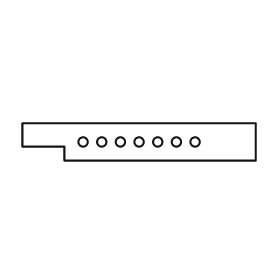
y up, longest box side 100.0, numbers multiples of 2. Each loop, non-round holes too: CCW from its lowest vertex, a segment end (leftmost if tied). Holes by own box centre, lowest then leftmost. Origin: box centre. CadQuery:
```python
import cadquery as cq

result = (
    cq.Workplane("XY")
    .moveTo(-32.0, -8.0)
    .lineTo(50.0, -8.0)
    .lineTo(50.0, 8.0)
    .lineTo(-50.0, 8.0)
    .lineTo(-50.0, -2.0)
    .lineTo(-32.0, -2.0)
    .close()
    .moveTo(-24.0, 0.0)
    .circle(2.0)
    .moveTo(-16.0, 0.0)
    .circle(2.0)
    .moveTo(-8.0, 0.0)
    .circle(2.0)
    .moveTo(0.0, 0.0)
    .circle(2.0)
    .moveTo(8.0, 0.0)
    .circle(2.0)
    .moveTo(16.0, 0.0)
    .circle(2.0)
    .moveTo(24.0, 0.0)
    .circle(2.0)
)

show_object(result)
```